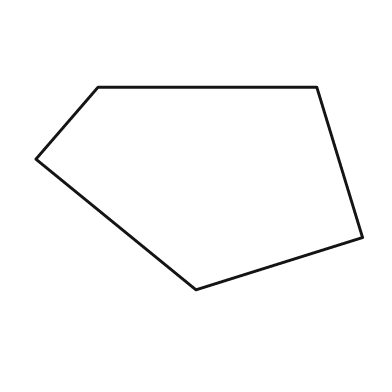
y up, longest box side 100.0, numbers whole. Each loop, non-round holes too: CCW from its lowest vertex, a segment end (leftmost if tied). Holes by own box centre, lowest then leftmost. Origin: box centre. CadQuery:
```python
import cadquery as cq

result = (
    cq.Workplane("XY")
    .moveTo(-1.0, -31.0)
    .lineTo(50.0, -15.0)
    .lineTo(36.0, 31.0)
    .lineTo(-31.0, 31.0)
    .lineTo(-50.0, 9.0)
    .close()
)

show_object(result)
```